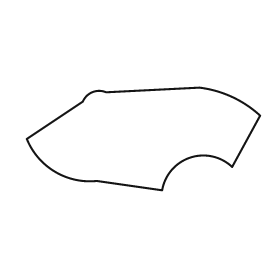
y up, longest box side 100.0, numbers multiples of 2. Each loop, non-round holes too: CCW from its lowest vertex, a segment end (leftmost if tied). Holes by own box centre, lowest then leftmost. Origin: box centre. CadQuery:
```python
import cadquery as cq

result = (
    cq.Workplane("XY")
    .moveTo(8.0, -22.0)
    .threePointArc((20.0, -8.0), (38.0, -12.0))
    .lineTo(50.0, 10.0)
    .threePointArc((38.0, 18.0), (24.0, 22.0))
    .lineTo(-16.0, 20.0)
    .threePointArc((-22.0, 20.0), (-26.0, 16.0))
    .lineTo(-50.0, 0.0)
    .threePointArc((-38.0, -14.0), (-20.0, -18.0))
    .close()
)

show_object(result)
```